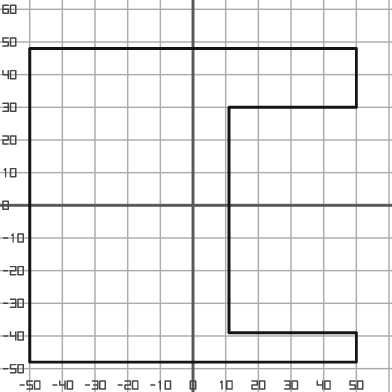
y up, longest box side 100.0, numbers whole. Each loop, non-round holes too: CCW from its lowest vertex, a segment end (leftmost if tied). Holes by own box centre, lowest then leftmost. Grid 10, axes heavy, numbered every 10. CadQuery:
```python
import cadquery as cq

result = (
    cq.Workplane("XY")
    .moveTo(-50.0, -48.0)
    .lineTo(50.0, -48.0)
    .lineTo(50.0, -39.0)
    .lineTo(11.0, -39.0)
    .lineTo(11.0, 30.0)
    .lineTo(50.0, 30.0)
    .lineTo(50.0, 48.0)
    .lineTo(-50.0, 48.0)
    .close()
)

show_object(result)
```